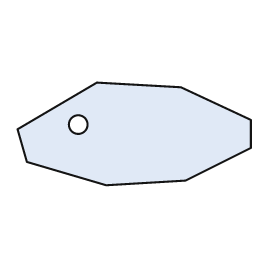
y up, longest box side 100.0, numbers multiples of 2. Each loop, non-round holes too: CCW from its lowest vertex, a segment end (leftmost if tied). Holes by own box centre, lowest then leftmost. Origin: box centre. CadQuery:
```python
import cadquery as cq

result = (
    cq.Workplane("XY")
    .moveTo(-12.0, -22.0)
    .lineTo(22.0, -20.0)
    .lineTo(50.0, -6.0)
    .lineTo(50.0, 6.0)
    .lineTo(20.0, 20.0)
    .lineTo(-16.0, 22.0)
    .lineTo(-50.0, 2.0)
    .lineTo(-46.0, -12.0)
    .close()
    .moveTo(-24.0, 4.0)
    .circle(4.0)
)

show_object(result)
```